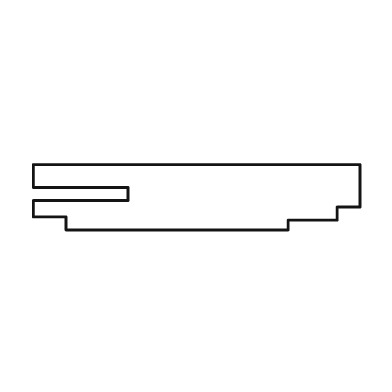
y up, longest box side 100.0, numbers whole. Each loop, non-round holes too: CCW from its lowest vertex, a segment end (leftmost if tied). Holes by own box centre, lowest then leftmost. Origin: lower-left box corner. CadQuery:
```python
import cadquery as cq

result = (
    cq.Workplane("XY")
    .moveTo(10.0, 0.0)
    .lineTo(78.0, 0.0)
    .lineTo(78.0, 3.0)
    .lineTo(93.0, 3.0)
    .lineTo(93.0, 7.0)
    .lineTo(100.0, 7.0)
    .lineTo(100.0, 20.0)
    .lineTo(0.0, 20.0)
    .lineTo(0.0, 13.0)
    .lineTo(29.0, 13.0)
    .lineTo(29.0, 9.0)
    .lineTo(0.0, 9.0)
    .lineTo(0.0, 4.0)
    .lineTo(10.0, 4.0)
    .close()
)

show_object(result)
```